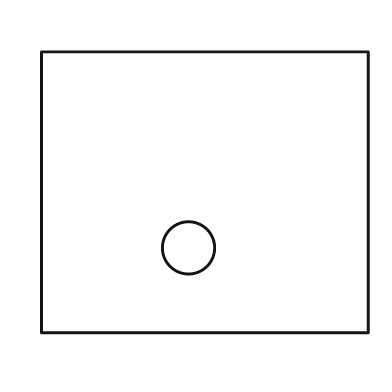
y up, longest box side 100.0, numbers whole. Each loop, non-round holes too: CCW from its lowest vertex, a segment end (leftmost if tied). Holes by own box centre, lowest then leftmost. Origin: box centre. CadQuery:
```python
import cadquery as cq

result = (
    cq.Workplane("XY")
    .moveTo(-50.0, -43.0)
    .lineTo(50.0, -43.0)
    .lineTo(50.0, 43.0)
    .lineTo(-50.0, 43.0)
    .close()
    .moveTo(-5.0, -17.0)
    .circle(8.0)
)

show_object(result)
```